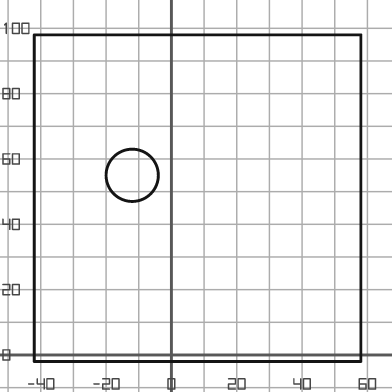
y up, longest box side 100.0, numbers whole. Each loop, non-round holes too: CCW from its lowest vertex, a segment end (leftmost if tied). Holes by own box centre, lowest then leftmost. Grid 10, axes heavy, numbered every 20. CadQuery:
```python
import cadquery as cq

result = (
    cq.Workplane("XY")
    .moveTo(-42.0, -2.0)
    .lineTo(58.0, -2.0)
    .lineTo(58.0, 98.0)
    .lineTo(-42.0, 98.0)
    .close()
    .moveTo(-12.0, 55.0)
    .circle(8.0)
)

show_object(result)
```